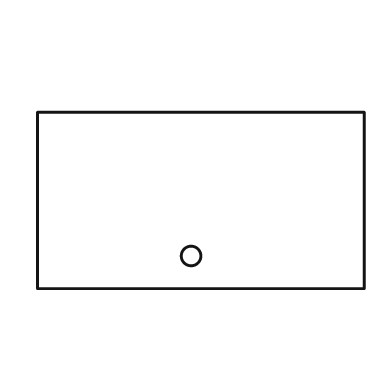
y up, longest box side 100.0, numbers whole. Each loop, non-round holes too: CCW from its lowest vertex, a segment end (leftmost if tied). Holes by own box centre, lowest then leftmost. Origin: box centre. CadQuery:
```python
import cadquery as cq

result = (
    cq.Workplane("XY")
    .moveTo(-50.0, -27.0)
    .lineTo(50.0, -27.0)
    .lineTo(50.0, 27.0)
    .lineTo(-50.0, 27.0)
    .close()
    .moveTo(-3.0, -17.0)
    .circle(3.0)
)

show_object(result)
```